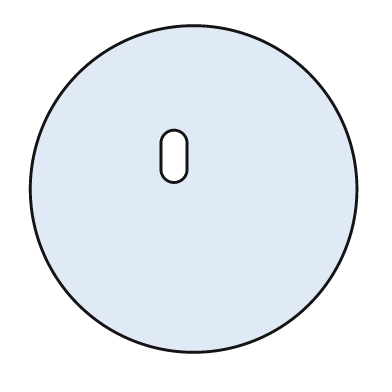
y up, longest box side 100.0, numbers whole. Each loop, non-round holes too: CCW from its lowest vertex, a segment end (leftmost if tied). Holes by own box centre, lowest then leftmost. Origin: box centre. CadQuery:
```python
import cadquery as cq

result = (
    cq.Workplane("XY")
    .moveTo(0.0, 0.0)
    .circle(50.0)
    .moveTo(-10.0, 6.0)
    .threePointArc((-6.0, 2.0), (-2.0, 6.0))
    .lineTo(-2.0, 14.0)
    .threePointArc((-6.0, 18.0), (-10.0, 14.0))
    .close()
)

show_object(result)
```